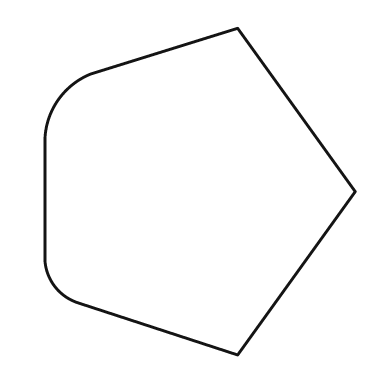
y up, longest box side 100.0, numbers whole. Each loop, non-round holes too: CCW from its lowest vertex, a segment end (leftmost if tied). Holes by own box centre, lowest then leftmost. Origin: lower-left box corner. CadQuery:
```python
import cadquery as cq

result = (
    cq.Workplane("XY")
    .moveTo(59.0, 0.0)
    .lineTo(95.0, 50.0)
    .lineTo(59.0, 100.0)
    .lineTo(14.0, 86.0)
    .threePointArc((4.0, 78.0), (0.0, 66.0))
    .lineTo(0.0, 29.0)
    .threePointArc((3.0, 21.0), (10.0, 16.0))
    .close()
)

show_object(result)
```